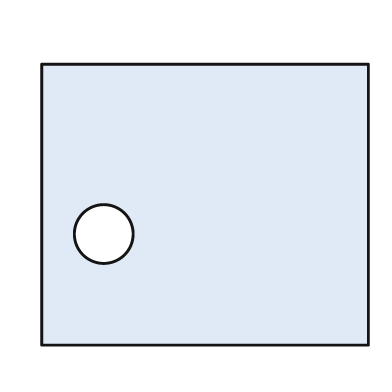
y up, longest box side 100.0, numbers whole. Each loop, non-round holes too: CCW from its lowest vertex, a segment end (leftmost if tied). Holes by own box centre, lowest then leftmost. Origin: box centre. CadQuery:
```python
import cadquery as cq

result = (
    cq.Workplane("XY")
    .moveTo(-50.0, -43.0)
    .lineTo(50.0, -43.0)
    .lineTo(50.0, 43.0)
    .lineTo(-50.0, 43.0)
    .close()
    .moveTo(-31.0, -9.0)
    .circle(9.0)
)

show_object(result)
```